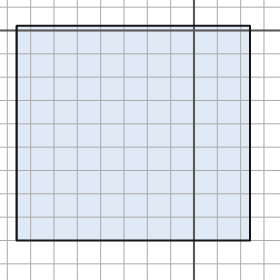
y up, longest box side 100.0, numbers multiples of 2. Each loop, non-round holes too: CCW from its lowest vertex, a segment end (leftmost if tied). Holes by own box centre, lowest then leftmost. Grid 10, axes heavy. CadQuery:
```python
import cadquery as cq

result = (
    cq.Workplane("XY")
    .moveTo(-76.0, -90.0)
    .lineTo(24.0, -90.0)
    .lineTo(24.0, 2.0)
    .lineTo(-76.0, 2.0)
    .close()
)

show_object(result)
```